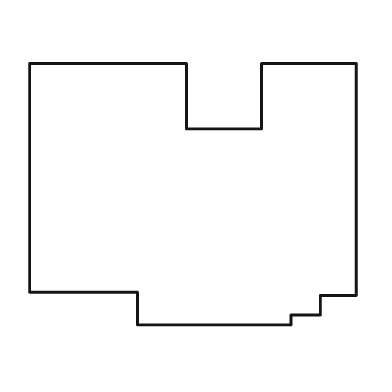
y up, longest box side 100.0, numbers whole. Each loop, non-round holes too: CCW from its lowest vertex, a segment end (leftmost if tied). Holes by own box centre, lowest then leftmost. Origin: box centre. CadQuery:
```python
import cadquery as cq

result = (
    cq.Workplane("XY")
    .moveTo(-17.0, -40.0)
    .lineTo(30.0, -40.0)
    .lineTo(30.0, -37.0)
    .lineTo(39.0, -37.0)
    .lineTo(39.0, -31.0)
    .lineTo(50.0, -31.0)
    .lineTo(50.0, 40.0)
    .lineTo(21.0, 40.0)
    .lineTo(21.0, 20.0)
    .lineTo(-2.0, 20.0)
    .lineTo(-2.0, 40.0)
    .lineTo(-50.0, 40.0)
    .lineTo(-50.0, -30.0)
    .lineTo(-17.0, -30.0)
    .close()
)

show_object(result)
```